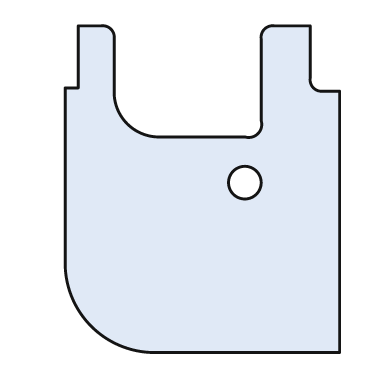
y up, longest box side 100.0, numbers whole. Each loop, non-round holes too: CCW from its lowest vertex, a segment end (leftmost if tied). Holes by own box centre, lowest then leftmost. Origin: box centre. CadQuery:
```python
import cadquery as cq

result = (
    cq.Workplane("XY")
    .moveTo(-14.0, -50.0)
    .lineTo(42.0, -50.0)
    .lineTo(42.0, 30.0)
    .lineTo(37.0, 30.0)
    .threePointArc((34.0, 31.0), (33.0, 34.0))
    .lineTo(33.0, 50.0)
    .lineTo(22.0, 50.0)
    .threePointArc((19.0, 49.0), (18.0, 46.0))
    .lineTo(18.0, 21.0)
    .threePointArc((17.0, 17.0), (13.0, 16.0))
    .lineTo(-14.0, 16.0)
    .threePointArc((-23.0, 20.0), (-27.0, 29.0))
    .lineTo(-27.0, 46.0)
    .threePointArc((-28.0, 49.0), (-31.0, 50.0))
    .lineTo(-38.0, 50.0)
    .lineTo(-38.0, 31.0)
    .lineTo(-42.0, 31.0)
    .lineTo(-42.0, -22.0)
    .threePointArc((-34.0, -42.0), (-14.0, -50.0))
    .close()
    .moveTo(13.0, 2.0)
    .circle(5.0)
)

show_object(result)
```